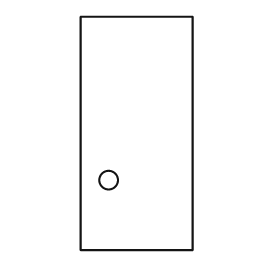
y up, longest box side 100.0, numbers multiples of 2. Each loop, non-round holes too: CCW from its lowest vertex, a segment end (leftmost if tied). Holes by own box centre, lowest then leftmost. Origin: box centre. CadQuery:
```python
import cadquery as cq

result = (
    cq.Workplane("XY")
    .moveTo(-24.0, -50.0)
    .lineTo(24.0, -50.0)
    .lineTo(24.0, 50.0)
    .lineTo(-24.0, 50.0)
    .close()
    .moveTo(-12.0, -20.0)
    .circle(4.0)
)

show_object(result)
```